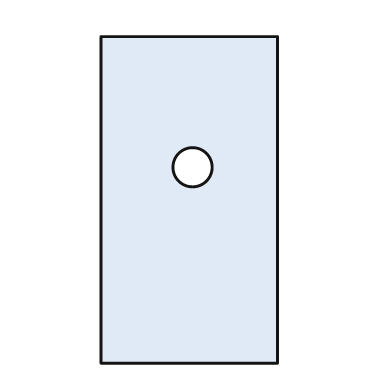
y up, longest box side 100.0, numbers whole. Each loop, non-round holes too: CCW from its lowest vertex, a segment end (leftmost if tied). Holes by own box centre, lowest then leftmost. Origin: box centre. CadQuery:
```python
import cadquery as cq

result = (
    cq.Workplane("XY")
    .moveTo(-27.0, -50.0)
    .lineTo(27.0, -50.0)
    .lineTo(27.0, 50.0)
    .lineTo(-27.0, 50.0)
    .close()
    .moveTo(1.0, 10.0)
    .circle(6.0)
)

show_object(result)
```